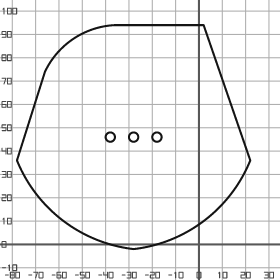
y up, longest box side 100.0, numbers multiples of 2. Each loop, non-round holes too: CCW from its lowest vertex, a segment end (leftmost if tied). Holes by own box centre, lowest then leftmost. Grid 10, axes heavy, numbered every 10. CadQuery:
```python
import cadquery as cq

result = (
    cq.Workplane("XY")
    .moveTo(-28.0, -2.0)
    .threePointArc((2.0, 10.0), (22.0, 36.0))
    .lineTo(2.0, 94.0)
    .lineTo(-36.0, 94.0)
    .threePointArc((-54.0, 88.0), (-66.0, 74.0))
    .lineTo(-78.0, 36.0)
    .threePointArc((-58.0, 10.0), (-28.0, -2.0))
    .close()
    .moveTo(-38.0, 46.0)
    .circle(2.0)
    .moveTo(-28.0, 46.0)
    .circle(2.0)
    .moveTo(-18.0, 46.0)
    .circle(2.0)
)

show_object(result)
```